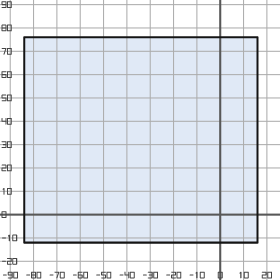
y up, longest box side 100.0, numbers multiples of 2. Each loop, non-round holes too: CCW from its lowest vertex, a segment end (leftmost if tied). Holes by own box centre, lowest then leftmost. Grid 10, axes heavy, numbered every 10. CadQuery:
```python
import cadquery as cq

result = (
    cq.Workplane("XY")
    .moveTo(-84.0, -12.0)
    .lineTo(16.0, -12.0)
    .lineTo(16.0, 76.0)
    .lineTo(-84.0, 76.0)
    .close()
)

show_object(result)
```